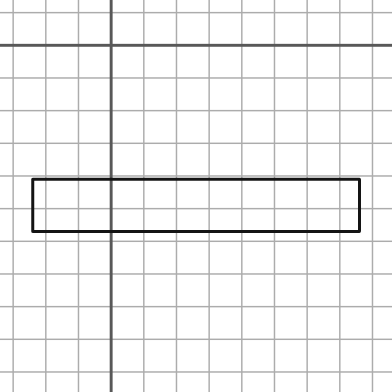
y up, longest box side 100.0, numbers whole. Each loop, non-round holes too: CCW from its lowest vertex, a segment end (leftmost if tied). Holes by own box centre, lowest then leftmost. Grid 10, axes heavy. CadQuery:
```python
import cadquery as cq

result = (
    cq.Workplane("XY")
    .moveTo(-24.0, -57.0)
    .lineTo(76.0, -57.0)
    .lineTo(76.0, -41.0)
    .lineTo(-24.0, -41.0)
    .close()
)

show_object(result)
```